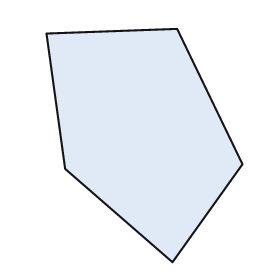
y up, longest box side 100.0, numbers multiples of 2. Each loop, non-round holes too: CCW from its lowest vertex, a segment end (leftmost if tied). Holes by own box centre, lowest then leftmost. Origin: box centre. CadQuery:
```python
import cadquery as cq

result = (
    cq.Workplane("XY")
    .moveTo(12.0, -50.0)
    .lineTo(42.0, -8.0)
    .lineTo(14.0, 50.0)
    .lineTo(-42.0, 48.0)
    .lineTo(-34.0, -10.0)
    .close()
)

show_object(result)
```